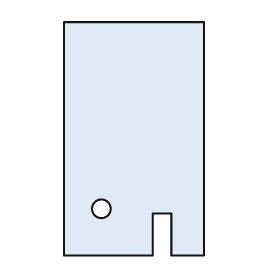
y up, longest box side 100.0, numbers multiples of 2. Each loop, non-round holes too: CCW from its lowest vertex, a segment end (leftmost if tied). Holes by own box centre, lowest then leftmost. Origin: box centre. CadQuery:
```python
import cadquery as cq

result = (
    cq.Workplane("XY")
    .moveTo(-30.0, -50.0)
    .lineTo(8.0, -50.0)
    .lineTo(8.0, -32.0)
    .lineTo(16.0, -32.0)
    .lineTo(16.0, -50.0)
    .lineTo(30.0, -50.0)
    .lineTo(30.0, 50.0)
    .lineTo(-30.0, 50.0)
    .close()
    .moveTo(-14.0, -30.0)
    .circle(4.0)
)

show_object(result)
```